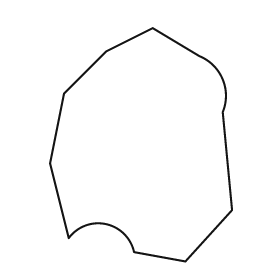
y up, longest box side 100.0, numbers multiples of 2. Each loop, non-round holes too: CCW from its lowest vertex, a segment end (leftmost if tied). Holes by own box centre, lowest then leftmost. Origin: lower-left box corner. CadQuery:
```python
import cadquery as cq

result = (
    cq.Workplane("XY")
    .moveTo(58.0, 0.0)
    .lineTo(78.0, 22.0)
    .lineTo(74.0, 64.0)
    .threePointArc((74.0, 78.0), (64.0, 88.0))
    .lineTo(44.0, 100.0)
    .lineTo(24.0, 90.0)
    .lineTo(6.0, 72.0)
    .lineTo(0.0, 42.0)
    .lineTo(8.0, 10.0)
    .threePointArc((24.0, 16.0), (36.0, 4.0))
    .close()
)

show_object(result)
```